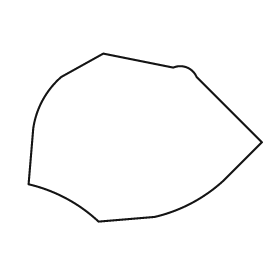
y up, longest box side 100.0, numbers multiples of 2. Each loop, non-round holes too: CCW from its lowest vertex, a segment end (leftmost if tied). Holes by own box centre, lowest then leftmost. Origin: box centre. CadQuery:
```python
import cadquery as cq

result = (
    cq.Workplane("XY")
    .moveTo(-20.0, -36.0)
    .lineTo(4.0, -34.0)
    .threePointArc((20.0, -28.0), (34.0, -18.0))
    .lineTo(50.0, -2.0)
    .lineTo(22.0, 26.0)
    .threePointArc((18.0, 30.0), (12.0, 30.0))
    .lineTo(-18.0, 36.0)
    .lineTo(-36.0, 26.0)
    .threePointArc((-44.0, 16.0), (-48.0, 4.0))
    .lineTo(-50.0, -20.0)
    .threePointArc((-34.0, -26.0), (-20.0, -36.0))
    .close()
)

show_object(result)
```